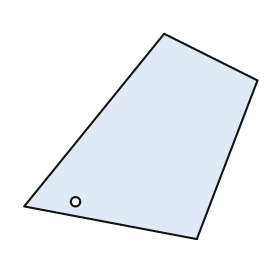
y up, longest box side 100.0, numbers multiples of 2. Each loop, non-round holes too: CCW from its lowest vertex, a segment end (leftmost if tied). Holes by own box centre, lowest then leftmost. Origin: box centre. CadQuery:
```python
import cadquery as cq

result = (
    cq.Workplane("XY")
    .moveTo(24.0, -44.0)
    .lineTo(50.0, 24.0)
    .lineTo(10.0, 44.0)
    .lineTo(-50.0, -30.0)
    .close()
    .moveTo(-28.0, -28.0)
    .circle(2.0)
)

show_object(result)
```